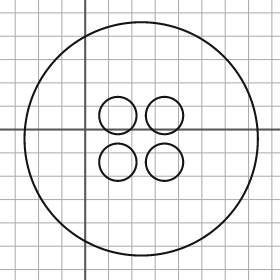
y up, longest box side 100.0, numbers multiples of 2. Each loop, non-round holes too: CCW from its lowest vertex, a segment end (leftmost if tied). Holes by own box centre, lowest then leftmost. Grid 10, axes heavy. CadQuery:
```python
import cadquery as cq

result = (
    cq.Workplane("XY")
    .moveTo(24.0, -4.0)
    .circle(50.0)
    .moveTo(14.0, -14.0)
    .circle(8.0)
    .moveTo(34.0, -14.0)
    .circle(8.0)
    .moveTo(14.0, 6.0)
    .circle(8.0)
    .moveTo(34.0, 6.0)
    .circle(8.0)
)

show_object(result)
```